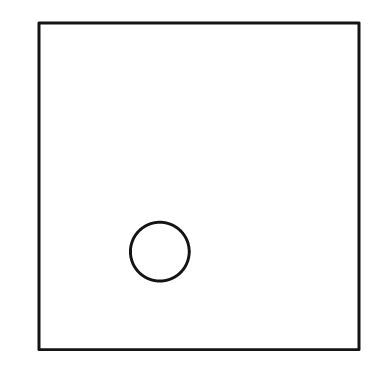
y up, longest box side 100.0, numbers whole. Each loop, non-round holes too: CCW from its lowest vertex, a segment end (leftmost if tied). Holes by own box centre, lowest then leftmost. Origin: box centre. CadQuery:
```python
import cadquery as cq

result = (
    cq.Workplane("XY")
    .moveTo(-49.0, -50.0)
    .lineTo(49.0, -50.0)
    .lineTo(49.0, 50.0)
    .lineTo(-49.0, 50.0)
    .close()
    .moveTo(-12.0, -20.0)
    .circle(9.0)
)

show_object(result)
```